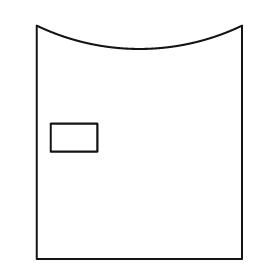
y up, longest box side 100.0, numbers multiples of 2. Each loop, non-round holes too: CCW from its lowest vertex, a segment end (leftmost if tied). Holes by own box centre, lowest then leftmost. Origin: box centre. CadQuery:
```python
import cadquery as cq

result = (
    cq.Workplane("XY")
    .moveTo(-44.0, -50.0)
    .lineTo(44.0, -50.0)
    .lineTo(44.0, 50.0)
    .threePointArc((0.0, 40.0), (-44.0, 50.0))
    .close()
    .moveTo(-38.0, -4.0)
    .lineTo(-18.0, -4.0)
    .lineTo(-18.0, 8.0)
    .lineTo(-38.0, 8.0)
    .close()
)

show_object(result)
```